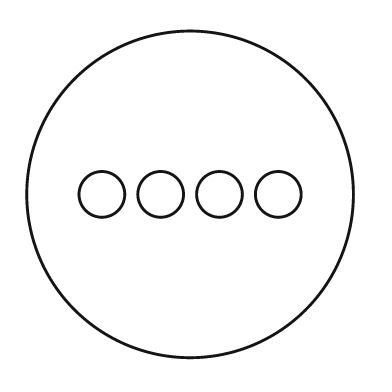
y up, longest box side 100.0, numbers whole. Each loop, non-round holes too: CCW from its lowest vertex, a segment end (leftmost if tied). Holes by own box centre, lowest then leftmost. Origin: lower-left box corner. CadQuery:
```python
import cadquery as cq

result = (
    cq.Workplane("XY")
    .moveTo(50.0, 50.0)
    .circle(50.0)
    .moveTo(23.0, 50.0)
    .circle(7.0)
    .moveTo(41.0, 50.0)
    .circle(7.0)
    .moveTo(59.0, 50.0)
    .circle(7.0)
    .moveTo(77.0, 50.0)
    .circle(7.0)
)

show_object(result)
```